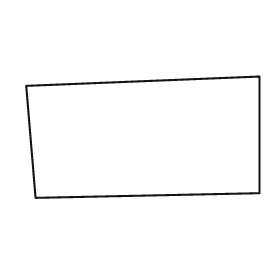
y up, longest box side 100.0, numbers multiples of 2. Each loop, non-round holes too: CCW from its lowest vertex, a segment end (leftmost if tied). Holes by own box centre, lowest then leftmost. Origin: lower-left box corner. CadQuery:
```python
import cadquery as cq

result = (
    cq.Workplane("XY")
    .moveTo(4.0, 0.0)
    .lineTo(100.0, 2.0)
    .lineTo(100.0, 52.0)
    .lineTo(0.0, 48.0)
    .close()
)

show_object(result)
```